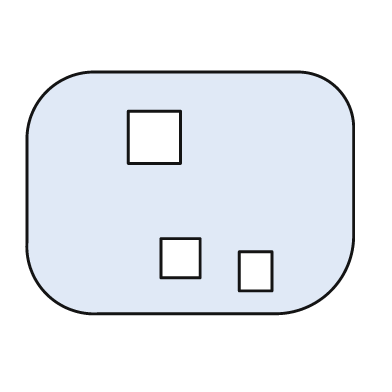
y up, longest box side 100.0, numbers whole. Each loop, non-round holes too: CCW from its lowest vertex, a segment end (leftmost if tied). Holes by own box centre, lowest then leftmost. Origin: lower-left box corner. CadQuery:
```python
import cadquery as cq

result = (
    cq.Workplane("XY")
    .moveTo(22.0, 0.0)
    .lineTo(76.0, 0.0)
    .threePointArc((93.0, 7.0), (100.0, 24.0))
    .lineTo(100.0, 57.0)
    .threePointArc((95.0, 69.0), (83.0, 74.0))
    .lineTo(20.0, 74.0)
    .threePointArc((6.0, 68.0), (0.0, 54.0))
    .lineTo(0.0, 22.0)
    .threePointArc((6.0, 6.0), (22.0, 0.0))
    .close()
    .moveTo(65.0, 7.0)
    .lineTo(75.0, 7.0)
    .lineTo(75.0, 19.0)
    .lineTo(65.0, 19.0)
    .close()
    .moveTo(41.0, 11.0)
    .lineTo(53.0, 11.0)
    .lineTo(53.0, 23.0)
    .lineTo(41.0, 23.0)
    .close()
    .moveTo(31.0, 46.0)
    .lineTo(47.0, 46.0)
    .lineTo(47.0, 62.0)
    .lineTo(31.0, 62.0)
    .close()
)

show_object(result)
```